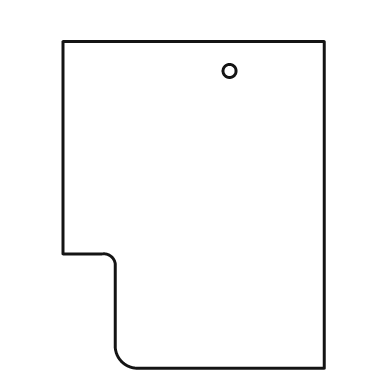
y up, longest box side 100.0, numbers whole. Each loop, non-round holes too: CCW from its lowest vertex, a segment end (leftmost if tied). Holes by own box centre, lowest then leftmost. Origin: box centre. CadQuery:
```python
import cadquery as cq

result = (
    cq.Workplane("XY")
    .moveTo(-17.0, -50.0)
    .lineTo(40.0, -50.0)
    .lineTo(40.0, 50.0)
    .lineTo(-40.0, 50.0)
    .lineTo(-40.0, -15.0)
    .lineTo(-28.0, -15.0)
    .threePointArc((-25.0, -16.0), (-24.0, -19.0))
    .lineTo(-24.0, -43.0)
    .threePointArc((-22.0, -48.0), (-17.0, -50.0))
    .close()
    .moveTo(11.0, 41.0)
    .circle(2.0)
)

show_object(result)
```